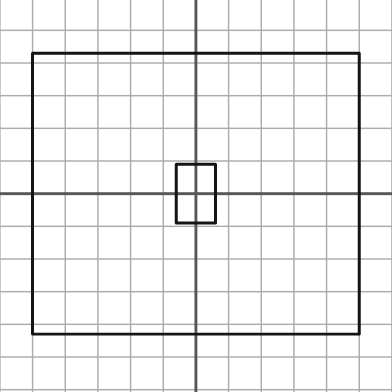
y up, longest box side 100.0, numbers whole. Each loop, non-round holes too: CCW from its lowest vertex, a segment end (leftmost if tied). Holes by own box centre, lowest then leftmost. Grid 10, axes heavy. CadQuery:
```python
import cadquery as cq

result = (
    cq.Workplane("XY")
    .moveTo(-50.0, -43.0)
    .lineTo(50.0, -43.0)
    .lineTo(50.0, 43.0)
    .lineTo(-50.0, 43.0)
    .close()
    .moveTo(-6.0, -9.0)
    .lineTo(6.0, -9.0)
    .lineTo(6.0, 9.0)
    .lineTo(-6.0, 9.0)
    .close()
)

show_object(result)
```